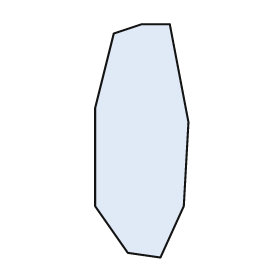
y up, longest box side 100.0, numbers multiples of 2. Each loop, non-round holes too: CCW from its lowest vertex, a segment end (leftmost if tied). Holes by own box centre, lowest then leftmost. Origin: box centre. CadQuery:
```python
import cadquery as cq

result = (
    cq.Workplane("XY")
    .moveTo(8.0, -50.0)
    .lineTo(18.0, -28.0)
    .lineTo(20.0, 8.0)
    .lineTo(12.0, 50.0)
    .lineTo(0.0, 50.0)
    .lineTo(-12.0, 46.0)
    .lineTo(-20.0, 14.0)
    .lineTo(-20.0, -28.0)
    .lineTo(-6.0, -48.0)
    .close()
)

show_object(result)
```